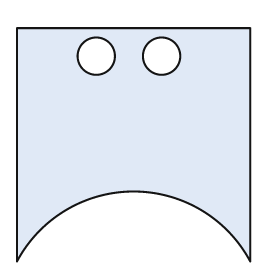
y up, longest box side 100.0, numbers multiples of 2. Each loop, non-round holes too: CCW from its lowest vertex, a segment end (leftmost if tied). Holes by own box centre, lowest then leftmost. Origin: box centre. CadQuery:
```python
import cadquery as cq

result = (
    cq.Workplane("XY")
    .moveTo(-50.0, -50.0)
    .threePointArc((0.0, -20.0), (50.0, -50.0))
    .lineTo(50.0, 50.0)
    .lineTo(-50.0, 50.0)
    .close()
    .moveTo(-16.0, 38.0)
    .circle(8.0)
    .moveTo(12.0, 38.0)
    .circle(8.0)
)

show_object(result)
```